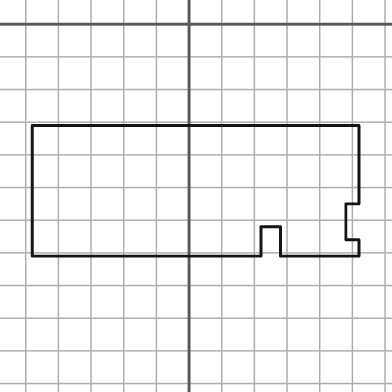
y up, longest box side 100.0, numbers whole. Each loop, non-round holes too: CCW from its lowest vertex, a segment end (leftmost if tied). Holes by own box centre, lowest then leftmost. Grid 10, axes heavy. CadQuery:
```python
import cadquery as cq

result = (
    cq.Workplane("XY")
    .moveTo(-48.0, -71.0)
    .lineTo(22.0, -71.0)
    .lineTo(22.0, -62.0)
    .lineTo(28.0, -62.0)
    .lineTo(28.0, -71.0)
    .lineTo(52.0, -71.0)
    .lineTo(52.0, -66.0)
    .lineTo(48.0, -66.0)
    .lineTo(48.0, -55.0)
    .lineTo(52.0, -55.0)
    .lineTo(52.0, -31.0)
    .lineTo(-48.0, -31.0)
    .close()
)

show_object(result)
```